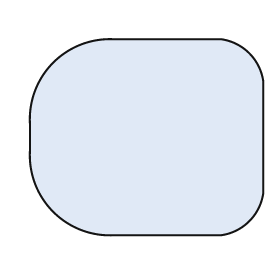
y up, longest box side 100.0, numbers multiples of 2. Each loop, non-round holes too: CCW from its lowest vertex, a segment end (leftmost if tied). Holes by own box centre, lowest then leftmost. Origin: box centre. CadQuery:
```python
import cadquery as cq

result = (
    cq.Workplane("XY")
    .moveTo(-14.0, -42.0)
    .lineTo(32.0, -42.0)
    .threePointArc((44.0, -36.0), (50.0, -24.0))
    .lineTo(50.0, 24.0)
    .threePointArc((44.0, 36.0), (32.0, 42.0))
    .lineTo(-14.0, 42.0)
    .threePointArc((-40.0, 32.0), (-50.0, 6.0))
    .lineTo(-50.0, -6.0)
    .threePointArc((-40.0, -32.0), (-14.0, -42.0))
    .close()
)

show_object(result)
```